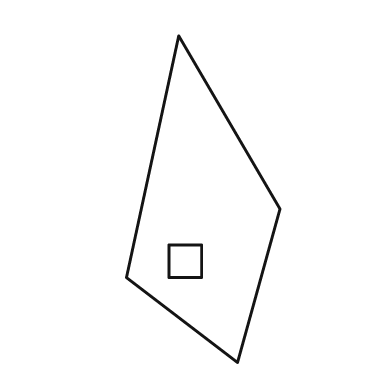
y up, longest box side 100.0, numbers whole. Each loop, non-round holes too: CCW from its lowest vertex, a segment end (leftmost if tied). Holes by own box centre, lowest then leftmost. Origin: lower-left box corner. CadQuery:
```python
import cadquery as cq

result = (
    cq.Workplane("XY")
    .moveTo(34.0, 0.0)
    .lineTo(47.0, 47.0)
    .lineTo(16.0, 100.0)
    .lineTo(0.0, 26.0)
    .close()
    .moveTo(13.0, 26.0)
    .lineTo(23.0, 26.0)
    .lineTo(23.0, 36.0)
    .lineTo(13.0, 36.0)
    .close()
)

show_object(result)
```